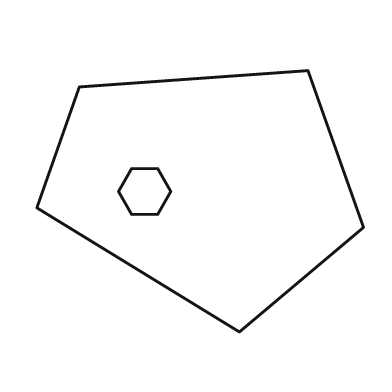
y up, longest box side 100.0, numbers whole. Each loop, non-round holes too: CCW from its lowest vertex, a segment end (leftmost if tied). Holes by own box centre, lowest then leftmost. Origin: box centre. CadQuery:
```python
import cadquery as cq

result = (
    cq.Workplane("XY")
    .moveTo(12.0, -40.0)
    .lineTo(50.0, -8.0)
    .lineTo(33.0, 40.0)
    .lineTo(-37.0, 35.0)
    .lineTo(-50.0, -2.0)
    .close()
    .moveTo(-21.0, -4.0)
    .lineTo(-13.0, -4.0)
    .lineTo(-9.0, 3.0)
    .lineTo(-13.0, 10.0)
    .lineTo(-21.0, 10.0)
    .lineTo(-25.0, 3.0)
    .close()
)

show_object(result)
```